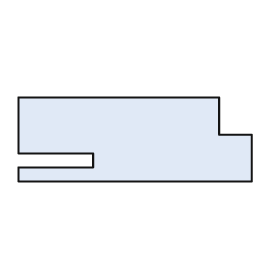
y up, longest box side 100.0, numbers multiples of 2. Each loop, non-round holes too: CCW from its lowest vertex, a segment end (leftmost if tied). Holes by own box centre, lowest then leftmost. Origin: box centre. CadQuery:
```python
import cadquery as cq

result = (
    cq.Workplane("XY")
    .moveTo(-50.0, -18.0)
    .lineTo(50.0, -18.0)
    .lineTo(50.0, 2.0)
    .lineTo(36.0, 2.0)
    .lineTo(36.0, 18.0)
    .lineTo(-50.0, 18.0)
    .lineTo(-50.0, -6.0)
    .lineTo(-18.0, -6.0)
    .lineTo(-18.0, -12.0)
    .lineTo(-50.0, -12.0)
    .close()
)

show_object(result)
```